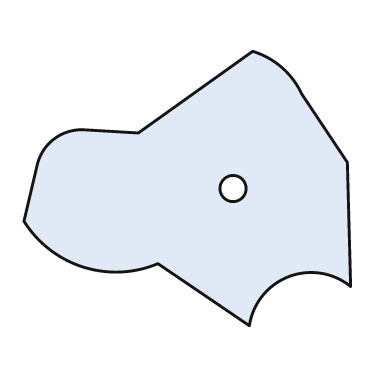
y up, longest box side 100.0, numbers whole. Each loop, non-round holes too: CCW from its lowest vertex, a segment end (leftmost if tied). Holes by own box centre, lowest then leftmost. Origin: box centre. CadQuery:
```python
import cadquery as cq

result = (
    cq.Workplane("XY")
    .moveTo(19.0, -42.0)
    .threePointArc((31.0, -27.0), (50.0, -30.0))
    .lineTo(49.0, 8.0)
    .lineTo(35.0, 29.0)
    .threePointArc((29.0, 37.0), (20.0, 42.0))
    .lineTo(-15.0, 17.0)
    .lineTo(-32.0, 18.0)
    .threePointArc((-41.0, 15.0), (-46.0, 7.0))
    .lineTo(-50.0, -10.0)
    .threePointArc((-32.0, -24.0), (-9.0, -23.0))
    .close()
    .moveTo(14.0, 0.0)
    .circle(4.0)
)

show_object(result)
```